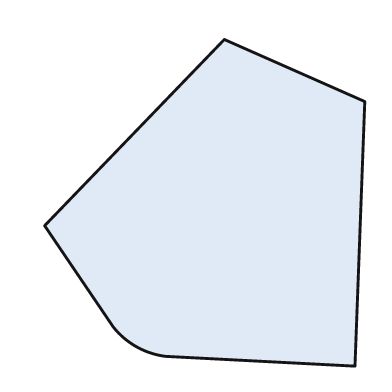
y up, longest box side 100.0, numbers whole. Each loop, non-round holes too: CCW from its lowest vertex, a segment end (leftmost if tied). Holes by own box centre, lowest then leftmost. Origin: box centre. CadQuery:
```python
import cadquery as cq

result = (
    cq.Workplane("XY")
    .moveTo(46.0, -50.0)
    .lineTo(49.0, 31.0)
    .lineTo(6.0, 50.0)
    .lineTo(-49.0, -7.0)
    .lineTo(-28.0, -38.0)
    .threePointArc((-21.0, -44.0), (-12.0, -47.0))
    .close()
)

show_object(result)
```